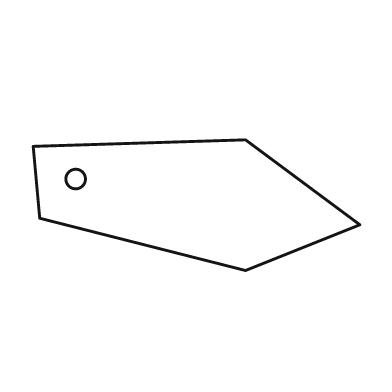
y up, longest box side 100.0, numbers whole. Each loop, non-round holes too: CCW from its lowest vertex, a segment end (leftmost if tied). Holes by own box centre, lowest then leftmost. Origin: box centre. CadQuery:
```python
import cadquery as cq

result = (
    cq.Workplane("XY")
    .moveTo(15.0, -20.0)
    .lineTo(50.0, -6.0)
    .lineTo(15.0, 20.0)
    .lineTo(-50.0, 18.0)
    .lineTo(-48.0, -4.0)
    .close()
    .moveTo(-37.0, 8.0)
    .circle(3.0)
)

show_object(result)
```